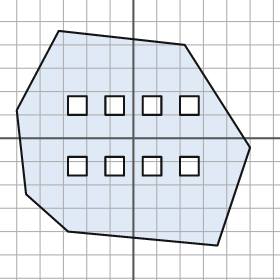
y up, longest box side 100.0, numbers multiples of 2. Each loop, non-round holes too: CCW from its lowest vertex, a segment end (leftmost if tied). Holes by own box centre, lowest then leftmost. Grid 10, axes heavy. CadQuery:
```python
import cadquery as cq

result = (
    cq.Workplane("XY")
    .moveTo(36.0, -46.0)
    .lineTo(50.0, -4.0)
    .lineTo(22.0, 40.0)
    .lineTo(-32.0, 46.0)
    .lineTo(-50.0, 12.0)
    .lineTo(-46.0, -24.0)
    .lineTo(-28.0, -40.0)
    .close()
    .moveTo(-28.0, -16.0)
    .lineTo(-20.0, -16.0)
    .lineTo(-20.0, -8.0)
    .lineTo(-28.0, -8.0)
    .close()
    .moveTo(-12.0, -16.0)
    .lineTo(-4.0, -16.0)
    .lineTo(-4.0, -8.0)
    .lineTo(-12.0, -8.0)
    .close()
    .moveTo(4.0, -16.0)
    .lineTo(12.0, -16.0)
    .lineTo(12.0, -8.0)
    .lineTo(4.0, -8.0)
    .close()
    .moveTo(20.0, -16.0)
    .lineTo(28.0, -16.0)
    .lineTo(28.0, -8.0)
    .lineTo(20.0, -8.0)
    .close()
    .moveTo(-28.0, 10.0)
    .lineTo(-20.0, 10.0)
    .lineTo(-20.0, 18.0)
    .lineTo(-28.0, 18.0)
    .close()
    .moveTo(-12.0, 10.0)
    .lineTo(-4.0, 10.0)
    .lineTo(-4.0, 18.0)
    .lineTo(-12.0, 18.0)
    .close()
    .moveTo(4.0, 10.0)
    .lineTo(12.0, 10.0)
    .lineTo(12.0, 18.0)
    .lineTo(4.0, 18.0)
    .close()
    .moveTo(20.0, 10.0)
    .lineTo(28.0, 10.0)
    .lineTo(28.0, 18.0)
    .lineTo(20.0, 18.0)
    .close()
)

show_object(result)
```